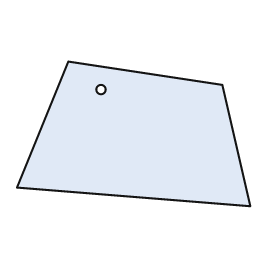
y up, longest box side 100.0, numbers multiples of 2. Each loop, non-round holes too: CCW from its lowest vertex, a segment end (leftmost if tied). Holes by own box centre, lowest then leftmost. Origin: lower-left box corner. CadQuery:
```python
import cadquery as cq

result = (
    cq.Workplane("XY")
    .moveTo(100.0, 0.0)
    .lineTo(88.0, 52.0)
    .lineTo(22.0, 62.0)
    .lineTo(0.0, 8.0)
    .close()
    .moveTo(36.0, 50.0)
    .circle(2.0)
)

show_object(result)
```